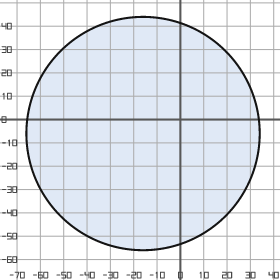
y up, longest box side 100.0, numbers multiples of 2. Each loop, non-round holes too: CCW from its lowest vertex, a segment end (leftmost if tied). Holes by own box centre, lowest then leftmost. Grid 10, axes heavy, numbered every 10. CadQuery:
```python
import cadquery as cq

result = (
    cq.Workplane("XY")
    .moveTo(-16.0, -6.0)
    .circle(50.0)
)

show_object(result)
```